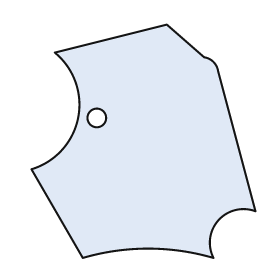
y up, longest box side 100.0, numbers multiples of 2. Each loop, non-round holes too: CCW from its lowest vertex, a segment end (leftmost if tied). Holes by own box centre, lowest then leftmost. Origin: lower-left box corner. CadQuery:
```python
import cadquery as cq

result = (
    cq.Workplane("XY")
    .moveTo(22.0, 0.0)
    .threePointArc((50.0, 4.0), (78.0, 0.0))
    .threePointArc((80.0, 16.0), (96.0, 20.0))
    .lineTo(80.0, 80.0)
    .threePointArc((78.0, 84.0), (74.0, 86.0))
    .lineTo(58.0, 100.0)
    .lineTo(10.0, 88.0)
    .threePointArc((20.0, 60.0), (0.0, 38.0))
    .close()
    .moveTo(28.0, 60.0)
    .circle(4.0)
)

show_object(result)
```